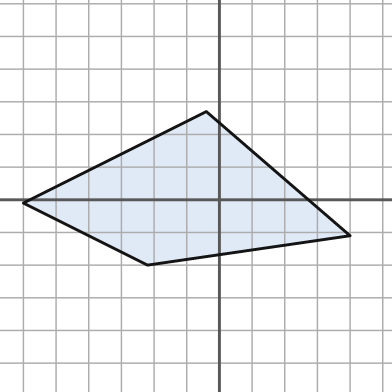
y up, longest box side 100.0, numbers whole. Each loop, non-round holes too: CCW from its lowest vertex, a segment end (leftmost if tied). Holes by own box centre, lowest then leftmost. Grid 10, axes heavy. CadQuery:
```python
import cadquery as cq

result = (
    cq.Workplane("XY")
    .moveTo(-22.0, -20.0)
    .lineTo(40.0, -11.0)
    .lineTo(-4.0, 27.0)
    .lineTo(-60.0, -1.0)
    .close()
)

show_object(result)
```